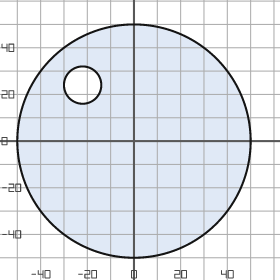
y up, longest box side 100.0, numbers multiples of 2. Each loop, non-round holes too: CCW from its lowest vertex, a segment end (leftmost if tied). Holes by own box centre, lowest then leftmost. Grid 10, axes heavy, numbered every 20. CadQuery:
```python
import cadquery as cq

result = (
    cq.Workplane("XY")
    .moveTo(0.0, 0.0)
    .circle(50.0)
    .moveTo(-22.0, 24.0)
    .circle(8.0)
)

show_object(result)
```